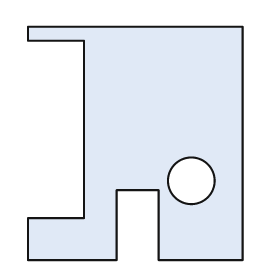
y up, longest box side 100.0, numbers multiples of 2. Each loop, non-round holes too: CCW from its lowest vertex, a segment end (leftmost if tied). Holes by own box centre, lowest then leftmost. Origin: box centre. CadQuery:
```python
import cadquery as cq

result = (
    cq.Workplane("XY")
    .moveTo(-46.0, -50.0)
    .lineTo(-8.0, -50.0)
    .lineTo(-8.0, -20.0)
    .lineTo(10.0, -20.0)
    .lineTo(10.0, -50.0)
    .lineTo(46.0, -50.0)
    .lineTo(46.0, 50.0)
    .lineTo(-46.0, 50.0)
    .lineTo(-46.0, 44.0)
    .lineTo(-22.0, 44.0)
    .lineTo(-22.0, -32.0)
    .lineTo(-46.0, -32.0)
    .close()
    .moveTo(24.0, -16.0)
    .circle(10.0)
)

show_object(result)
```